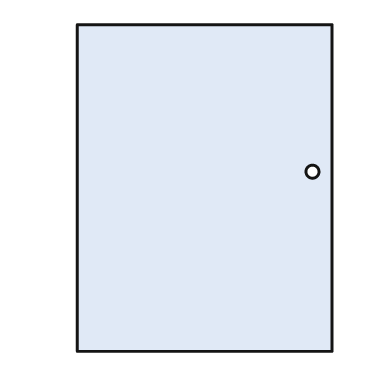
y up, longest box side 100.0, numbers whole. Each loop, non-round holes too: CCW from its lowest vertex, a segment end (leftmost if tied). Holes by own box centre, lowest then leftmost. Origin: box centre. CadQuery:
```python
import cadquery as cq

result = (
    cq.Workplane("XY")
    .moveTo(-39.0, -50.0)
    .lineTo(39.0, -50.0)
    .lineTo(39.0, 50.0)
    .lineTo(-39.0, 50.0)
    .close()
    .moveTo(33.0, 5.0)
    .circle(2.0)
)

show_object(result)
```